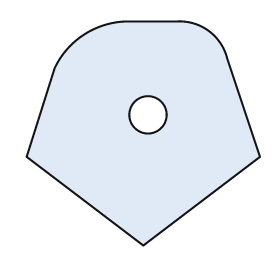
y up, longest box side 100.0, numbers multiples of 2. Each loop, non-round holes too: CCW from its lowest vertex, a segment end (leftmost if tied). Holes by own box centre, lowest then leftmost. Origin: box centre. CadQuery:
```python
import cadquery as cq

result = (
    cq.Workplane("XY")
    .moveTo(0.0, -48.0)
    .lineTo(50.0, -10.0)
    .lineTo(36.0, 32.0)
    .threePointArc((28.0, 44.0), (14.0, 48.0))
    .lineTo(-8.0, 48.0)
    .threePointArc((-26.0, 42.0), (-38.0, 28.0))
    .lineTo(-50.0, -10.0)
    .close()
    .moveTo(2.0, 8.0)
    .circle(8.0)
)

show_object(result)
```